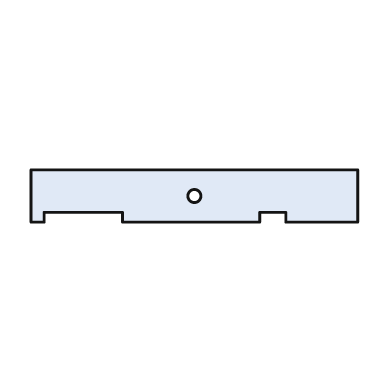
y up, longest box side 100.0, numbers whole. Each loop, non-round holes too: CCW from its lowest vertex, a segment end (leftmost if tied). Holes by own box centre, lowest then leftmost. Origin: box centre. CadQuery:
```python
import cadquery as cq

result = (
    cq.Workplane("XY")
    .moveTo(-50.0, -8.0)
    .lineTo(-46.0, -8.0)
    .lineTo(-46.0, -5.0)
    .lineTo(-22.0, -5.0)
    .lineTo(-22.0, -8.0)
    .lineTo(20.0, -8.0)
    .lineTo(20.0, -5.0)
    .lineTo(28.0, -5.0)
    .lineTo(28.0, -8.0)
    .lineTo(50.0, -8.0)
    .lineTo(50.0, 8.0)
    .lineTo(-50.0, 8.0)
    .close()
    .moveTo(0.0, 0.0)
    .circle(2.0)
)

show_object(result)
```